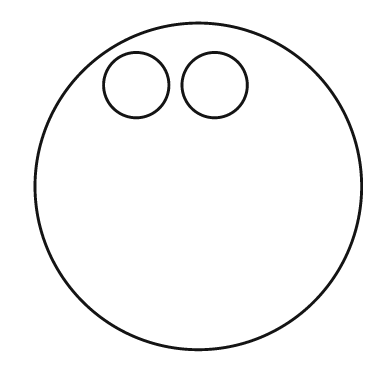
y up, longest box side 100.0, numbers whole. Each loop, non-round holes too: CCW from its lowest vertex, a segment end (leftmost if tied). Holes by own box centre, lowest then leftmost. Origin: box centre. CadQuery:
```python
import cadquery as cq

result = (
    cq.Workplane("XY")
    .moveTo(0.0, 0.0)
    .circle(50.0)
    .moveTo(-19.0, 31.0)
    .circle(10.0)
    .moveTo(5.0, 31.0)
    .circle(10.0)
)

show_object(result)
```